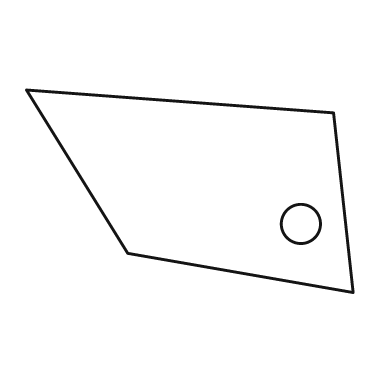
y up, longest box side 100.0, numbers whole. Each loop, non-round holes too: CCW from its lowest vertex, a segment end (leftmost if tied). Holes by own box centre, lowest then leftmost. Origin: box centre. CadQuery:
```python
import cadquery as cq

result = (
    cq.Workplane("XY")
    .moveTo(50.0, -31.0)
    .lineTo(44.0, 24.0)
    .lineTo(-50.0, 31.0)
    .lineTo(-19.0, -19.0)
    .close()
    .moveTo(34.0, -10.0)
    .circle(6.0)
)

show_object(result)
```